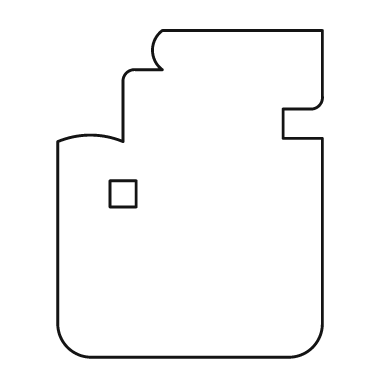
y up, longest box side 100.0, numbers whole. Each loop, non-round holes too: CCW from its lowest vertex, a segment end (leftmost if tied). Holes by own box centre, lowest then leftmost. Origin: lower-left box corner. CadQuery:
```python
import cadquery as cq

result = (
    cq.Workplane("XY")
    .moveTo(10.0, 0.0)
    .lineTo(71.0, 0.0)
    .threePointArc((78.0, 3.0), (81.0, 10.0))
    .lineTo(81.0, 67.0)
    .lineTo(69.0, 67.0)
    .lineTo(69.0, 76.0)
    .lineTo(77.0, 76.0)
    .threePointArc((80.0, 77.0), (81.0, 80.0))
    .lineTo(81.0, 100.0)
    .lineTo(32.0, 100.0)
    .threePointArc((29.0, 94.0), (32.0, 88.0))
    .lineTo(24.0, 88.0)
    .threePointArc((21.0, 87.0), (20.0, 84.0))
    .lineTo(20.0, 66.0)
    .threePointArc((10.0, 68.0), (0.0, 66.0))
    .lineTo(0.0, 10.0)
    .threePointArc((3.0, 3.0), (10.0, 0.0))
    .close()
    .moveTo(16.0, 46.0)
    .lineTo(24.0, 46.0)
    .lineTo(24.0, 54.0)
    .lineTo(16.0, 54.0)
    .close()
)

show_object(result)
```